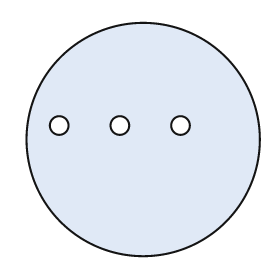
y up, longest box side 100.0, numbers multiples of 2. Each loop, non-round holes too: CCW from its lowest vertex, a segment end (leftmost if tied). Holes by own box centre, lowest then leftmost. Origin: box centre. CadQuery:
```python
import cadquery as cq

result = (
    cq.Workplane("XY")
    .moveTo(0.0, 0.0)
    .circle(50.0)
    .moveTo(-36.0, 6.0)
    .circle(4.0)
    .moveTo(-10.0, 6.0)
    .circle(4.0)
    .moveTo(16.0, 6.0)
    .circle(4.0)
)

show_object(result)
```